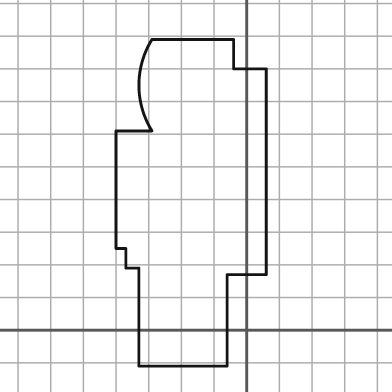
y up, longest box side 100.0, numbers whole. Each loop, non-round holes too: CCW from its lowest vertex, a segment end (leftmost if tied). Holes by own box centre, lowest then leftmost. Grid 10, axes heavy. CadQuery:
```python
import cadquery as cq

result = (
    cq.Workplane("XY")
    .moveTo(-33.0, -11.0)
    .lineTo(-6.0, -11.0)
    .lineTo(-6.0, 17.0)
    .lineTo(6.0, 17.0)
    .lineTo(6.0, 80.0)
    .lineTo(-4.0, 80.0)
    .lineTo(-4.0, 89.0)
    .lineTo(-29.0, 89.0)
    .threePointArc((-33.0, 75.0), (-29.0, 61.0))
    .lineTo(-40.0, 61.0)
    .lineTo(-40.0, 25.0)
    .lineTo(-37.0, 25.0)
    .lineTo(-37.0, 19.0)
    .lineTo(-33.0, 19.0)
    .close()
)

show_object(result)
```